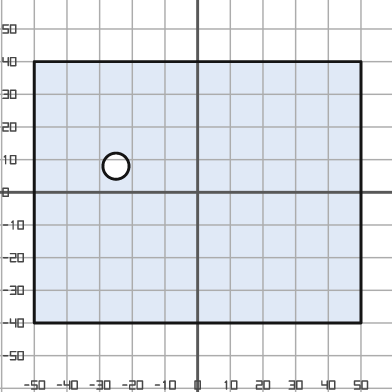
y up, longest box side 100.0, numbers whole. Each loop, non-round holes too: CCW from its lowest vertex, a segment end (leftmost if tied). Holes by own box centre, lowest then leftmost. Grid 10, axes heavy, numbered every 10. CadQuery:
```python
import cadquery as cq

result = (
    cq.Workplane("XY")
    .moveTo(-50.0, -40.0)
    .lineTo(50.0, -40.0)
    .lineTo(50.0, 40.0)
    .lineTo(-50.0, 40.0)
    .close()
    .moveTo(-25.0, 8.0)
    .circle(4.0)
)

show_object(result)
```